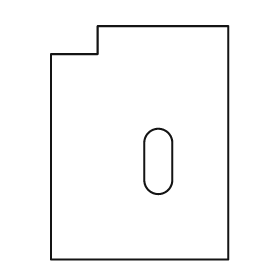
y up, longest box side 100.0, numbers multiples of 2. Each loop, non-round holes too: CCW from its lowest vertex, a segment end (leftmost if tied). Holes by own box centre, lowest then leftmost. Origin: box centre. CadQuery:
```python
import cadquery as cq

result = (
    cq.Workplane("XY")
    .moveTo(-38.0, -50.0)
    .lineTo(38.0, -50.0)
    .lineTo(38.0, 50.0)
    .lineTo(-18.0, 50.0)
    .lineTo(-18.0, 38.0)
    .lineTo(-38.0, 38.0)
    .close()
    .moveTo(2.0, -16.0)
    .threePointArc((8.0, -22.0), (14.0, -16.0))
    .lineTo(14.0, 0.0)
    .threePointArc((8.0, 6.0), (2.0, 0.0))
    .close()
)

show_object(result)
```